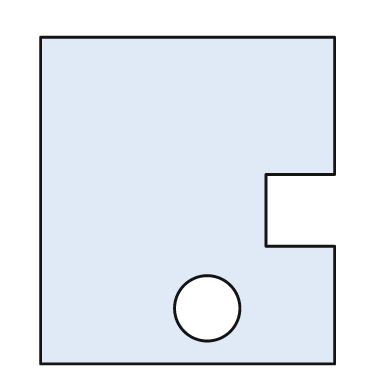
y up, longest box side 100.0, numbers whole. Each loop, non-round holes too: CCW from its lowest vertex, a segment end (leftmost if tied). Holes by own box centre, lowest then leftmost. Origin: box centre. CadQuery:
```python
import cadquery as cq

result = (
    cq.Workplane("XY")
    .moveTo(-45.0, -50.0)
    .lineTo(45.0, -50.0)
    .lineTo(45.0, -14.0)
    .lineTo(24.0, -14.0)
    .lineTo(24.0, 8.0)
    .lineTo(45.0, 8.0)
    .lineTo(45.0, 50.0)
    .lineTo(-45.0, 50.0)
    .close()
    .moveTo(6.0, -33.0)
    .circle(10.0)
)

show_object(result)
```